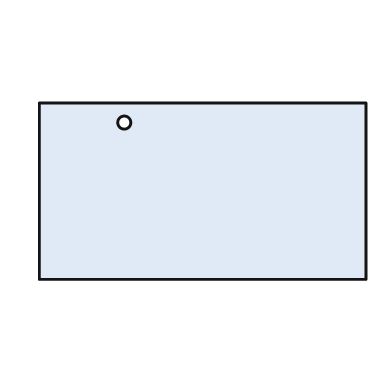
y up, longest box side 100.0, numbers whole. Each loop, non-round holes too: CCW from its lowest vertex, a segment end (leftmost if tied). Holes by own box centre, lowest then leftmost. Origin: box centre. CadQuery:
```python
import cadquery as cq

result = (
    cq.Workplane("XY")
    .moveTo(-50.0, -27.0)
    .lineTo(50.0, -27.0)
    .lineTo(50.0, 27.0)
    .lineTo(-50.0, 27.0)
    .close()
    .moveTo(-24.0, 21.0)
    .circle(2.0)
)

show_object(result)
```